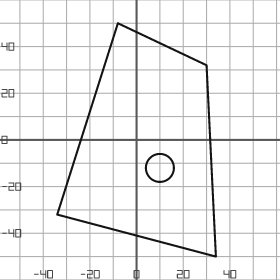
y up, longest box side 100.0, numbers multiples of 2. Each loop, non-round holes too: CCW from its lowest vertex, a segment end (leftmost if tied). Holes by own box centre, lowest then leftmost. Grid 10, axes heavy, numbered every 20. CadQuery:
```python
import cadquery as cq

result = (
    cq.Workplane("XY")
    .moveTo(34.0, -50.0)
    .lineTo(30.0, 32.0)
    .lineTo(-8.0, 50.0)
    .lineTo(-34.0, -32.0)
    .close()
    .moveTo(10.0, -12.0)
    .circle(6.0)
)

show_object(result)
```